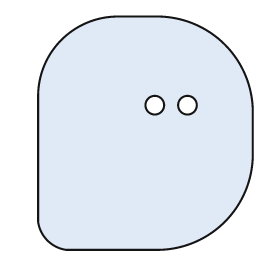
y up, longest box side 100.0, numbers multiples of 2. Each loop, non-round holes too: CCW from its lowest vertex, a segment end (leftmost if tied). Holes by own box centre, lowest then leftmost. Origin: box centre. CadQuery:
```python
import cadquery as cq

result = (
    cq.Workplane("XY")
    .moveTo(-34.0, -50.0)
    .lineTo(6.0, -50.0)
    .threePointArc((34.0, -38.0), (46.0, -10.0))
    .lineTo(46.0, 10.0)
    .threePointArc((34.0, 38.0), (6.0, 50.0))
    .lineTo(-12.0, 50.0)
    .threePointArc((-36.0, 40.0), (-46.0, 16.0))
    .lineTo(-46.0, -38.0)
    .threePointArc((-42.0, -46.0), (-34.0, -50.0))
    .close()
    .moveTo(4.0, 12.0)
    .circle(4.0)
    .moveTo(18.0, 12.0)
    .circle(4.0)
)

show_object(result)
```